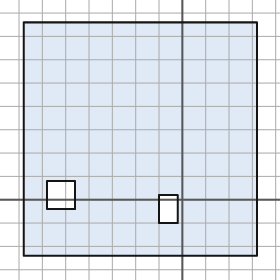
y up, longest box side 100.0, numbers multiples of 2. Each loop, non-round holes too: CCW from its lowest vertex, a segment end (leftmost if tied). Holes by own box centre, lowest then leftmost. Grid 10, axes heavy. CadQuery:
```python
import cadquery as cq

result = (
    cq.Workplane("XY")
    .moveTo(-68.0, -24.0)
    .lineTo(32.0, -24.0)
    .lineTo(32.0, 76.0)
    .lineTo(-68.0, 76.0)
    .close()
    .moveTo(-10.0, -10.0)
    .lineTo(-2.0, -10.0)
    .lineTo(-2.0, 2.0)
    .lineTo(-10.0, 2.0)
    .close()
    .moveTo(-58.0, -4.0)
    .lineTo(-46.0, -4.0)
    .lineTo(-46.0, 8.0)
    .lineTo(-58.0, 8.0)
    .close()
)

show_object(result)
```